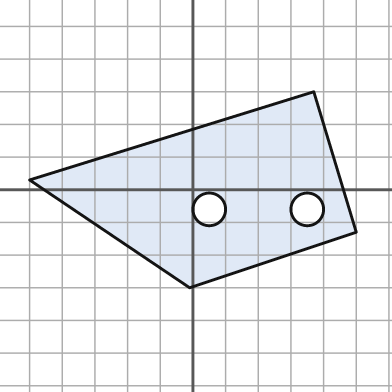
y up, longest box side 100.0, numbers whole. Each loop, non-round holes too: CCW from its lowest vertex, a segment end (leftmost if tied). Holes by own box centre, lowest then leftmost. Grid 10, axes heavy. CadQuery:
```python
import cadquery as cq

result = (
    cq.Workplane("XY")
    .moveTo(-1.0, -30.0)
    .lineTo(50.0, -13.0)
    .lineTo(37.0, 30.0)
    .lineTo(-50.0, 3.0)
    .close()
    .moveTo(5.0, -6.0)
    .circle(5.0)
    .moveTo(35.0, -6.0)
    .circle(5.0)
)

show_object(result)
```